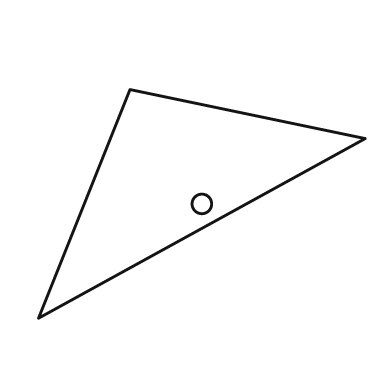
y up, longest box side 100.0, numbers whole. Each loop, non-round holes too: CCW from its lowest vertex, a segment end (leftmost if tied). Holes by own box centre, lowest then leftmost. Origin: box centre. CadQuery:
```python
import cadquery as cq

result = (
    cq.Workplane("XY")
    .moveTo(-50.0, -35.0)
    .lineTo(50.0, 20.0)
    .lineTo(-22.0, 35.0)
    .close()
    .moveTo(0.0, 0.0)
    .circle(3.0)
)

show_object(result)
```